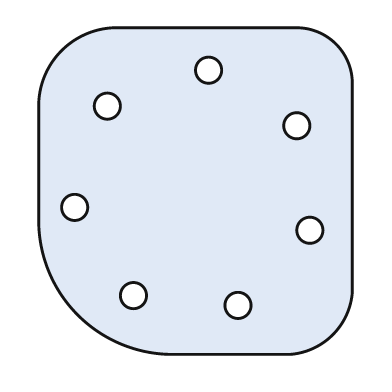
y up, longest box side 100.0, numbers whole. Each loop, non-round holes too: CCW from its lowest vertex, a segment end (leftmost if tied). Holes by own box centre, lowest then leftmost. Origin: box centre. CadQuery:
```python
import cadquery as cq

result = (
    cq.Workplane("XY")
    .moveTo(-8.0, -50.0)
    .lineTo(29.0, -50.0)
    .threePointArc((42.0, -44.0), (48.0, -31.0))
    .lineTo(48.0, 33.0)
    .threePointArc((43.0, 45.0), (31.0, 50.0))
    .lineTo(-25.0, 50.0)
    .threePointArc((-41.0, 43.0), (-48.0, 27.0))
    .lineTo(-48.0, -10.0)
    .threePointArc((-36.0, -38.0), (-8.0, -50.0))
    .close()
    .moveTo(13.0, -35.0)
    .circle(4.0)
    .moveTo(-19.0, -32.0)
    .circle(4.0)
    .moveTo(35.0, -12.0)
    .circle(4.0)
    .moveTo(-37.0, -5.0)
    .circle(4.0)
    .moveTo(31.0, 20.0)
    .circle(4.0)
    .moveTo(-27.0, 26.0)
    .circle(4.0)
    .moveTo(4.0, 37.0)
    .circle(4.0)
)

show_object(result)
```